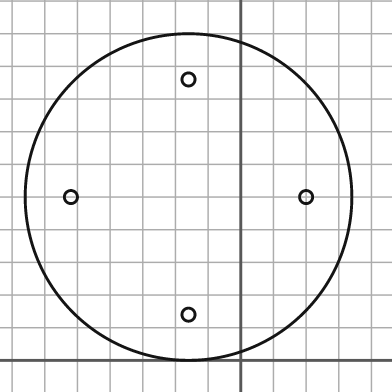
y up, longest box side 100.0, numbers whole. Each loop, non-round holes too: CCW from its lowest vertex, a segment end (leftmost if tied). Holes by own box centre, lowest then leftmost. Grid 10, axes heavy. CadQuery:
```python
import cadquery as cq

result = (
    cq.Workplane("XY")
    .moveTo(-16.0, 50.0)
    .circle(50.0)
    .moveTo(-16.0, 14.0)
    .circle(2.0)
    .moveTo(-52.0, 50.0)
    .circle(2.0)
    .moveTo(20.0, 50.0)
    .circle(2.0)
    .moveTo(-16.0, 86.0)
    .circle(2.0)
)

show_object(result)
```